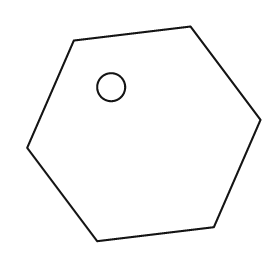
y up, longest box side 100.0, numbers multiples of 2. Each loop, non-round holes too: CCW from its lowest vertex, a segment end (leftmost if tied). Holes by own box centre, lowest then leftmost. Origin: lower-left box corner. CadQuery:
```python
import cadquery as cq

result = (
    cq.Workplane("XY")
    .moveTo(30.0, 0.0)
    .lineTo(80.0, 6.0)
    .lineTo(100.0, 52.0)
    .lineTo(70.0, 92.0)
    .lineTo(20.0, 86.0)
    .lineTo(0.0, 40.0)
    .close()
    .moveTo(36.0, 66.0)
    .circle(6.0)
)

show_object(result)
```